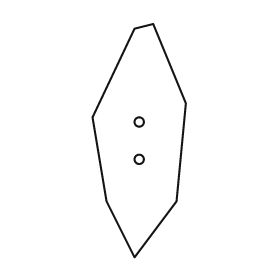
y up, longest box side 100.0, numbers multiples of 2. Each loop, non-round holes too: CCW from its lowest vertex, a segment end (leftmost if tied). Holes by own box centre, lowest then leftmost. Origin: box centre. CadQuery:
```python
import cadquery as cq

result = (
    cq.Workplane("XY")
    .moveTo(-2.0, -50.0)
    .lineTo(16.0, -26.0)
    .lineTo(20.0, 16.0)
    .lineTo(6.0, 50.0)
    .lineTo(-2.0, 48.0)
    .lineTo(-20.0, 10.0)
    .lineTo(-14.0, -26.0)
    .close()
    .moveTo(0.0, -8.0)
    .circle(2.0)
    .moveTo(0.0, 8.0)
    .circle(2.0)
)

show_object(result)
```